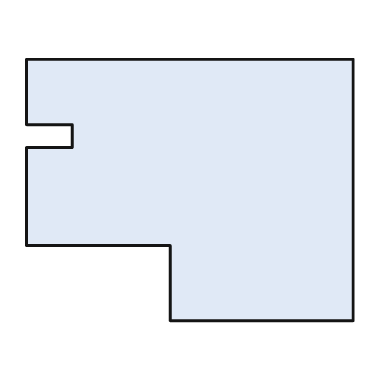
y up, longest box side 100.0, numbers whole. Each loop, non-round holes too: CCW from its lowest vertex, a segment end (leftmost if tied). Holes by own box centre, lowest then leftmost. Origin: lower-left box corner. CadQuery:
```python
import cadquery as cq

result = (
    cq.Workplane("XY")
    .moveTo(44.0, 0.0)
    .lineTo(100.0, 0.0)
    .lineTo(100.0, 80.0)
    .lineTo(0.0, 80.0)
    .lineTo(0.0, 60.0)
    .lineTo(14.0, 60.0)
    .lineTo(14.0, 53.0)
    .lineTo(0.0, 53.0)
    .lineTo(0.0, 23.0)
    .lineTo(44.0, 23.0)
    .close()
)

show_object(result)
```